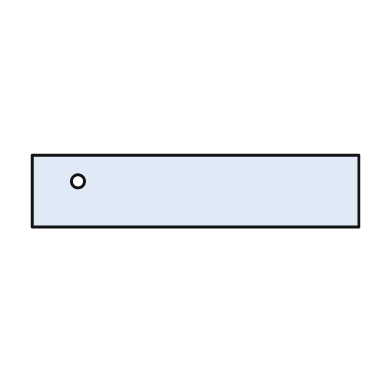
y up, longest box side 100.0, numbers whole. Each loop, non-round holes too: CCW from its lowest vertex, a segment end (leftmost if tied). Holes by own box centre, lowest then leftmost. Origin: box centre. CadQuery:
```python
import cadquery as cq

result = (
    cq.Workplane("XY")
    .moveTo(-50.0, -11.0)
    .lineTo(50.0, -11.0)
    .lineTo(50.0, 11.0)
    .lineTo(-50.0, 11.0)
    .close()
    .moveTo(-36.0, 3.0)
    .circle(2.0)
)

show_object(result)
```